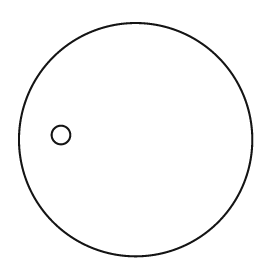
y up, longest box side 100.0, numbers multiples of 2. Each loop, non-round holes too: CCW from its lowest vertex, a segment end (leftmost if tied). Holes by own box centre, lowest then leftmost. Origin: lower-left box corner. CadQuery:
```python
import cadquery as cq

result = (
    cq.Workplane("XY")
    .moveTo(50.0, 50.0)
    .circle(50.0)
    .moveTo(18.0, 52.0)
    .circle(4.0)
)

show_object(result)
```